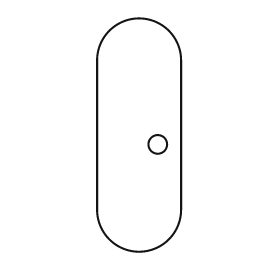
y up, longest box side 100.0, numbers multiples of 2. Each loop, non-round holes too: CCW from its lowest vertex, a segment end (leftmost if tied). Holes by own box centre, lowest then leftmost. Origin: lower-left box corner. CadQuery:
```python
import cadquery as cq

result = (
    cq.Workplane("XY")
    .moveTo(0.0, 18.0)
    .threePointArc((18.0, 0.0), (36.0, 18.0))
    .lineTo(36.0, 82.0)
    .threePointArc((18.0, 100.0), (0.0, 82.0))
    .close()
    .moveTo(26.0, 46.0)
    .circle(4.0)
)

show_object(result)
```